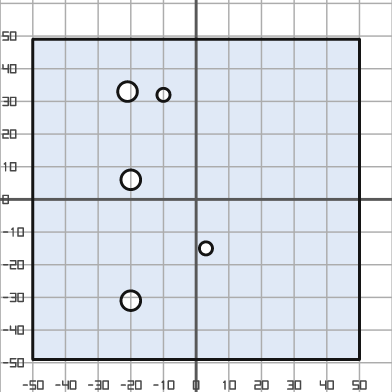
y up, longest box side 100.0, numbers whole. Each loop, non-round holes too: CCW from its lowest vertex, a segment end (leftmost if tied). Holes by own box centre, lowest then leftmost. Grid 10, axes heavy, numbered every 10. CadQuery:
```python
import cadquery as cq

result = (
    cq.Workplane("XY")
    .moveTo(-50.0, -49.0)
    .lineTo(50.0, -49.0)
    .lineTo(50.0, 49.0)
    .lineTo(-50.0, 49.0)
    .close()
    .moveTo(-20.0, -31.0)
    .circle(3.0)
    .moveTo(3.0, -15.0)
    .circle(2.0)
    .moveTo(-20.0, 6.0)
    .circle(3.0)
    .moveTo(-10.0, 32.0)
    .circle(2.0)
    .moveTo(-21.0, 33.0)
    .circle(3.0)
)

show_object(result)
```